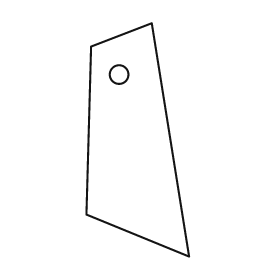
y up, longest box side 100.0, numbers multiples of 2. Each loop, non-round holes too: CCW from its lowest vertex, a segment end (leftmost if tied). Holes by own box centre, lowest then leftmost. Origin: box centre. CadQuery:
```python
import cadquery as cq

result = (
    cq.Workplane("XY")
    .moveTo(22.0, -50.0)
    .lineTo(6.0, 50.0)
    .lineTo(-20.0, 40.0)
    .lineTo(-22.0, -32.0)
    .close()
    .moveTo(-8.0, 28.0)
    .circle(4.0)
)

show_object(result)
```